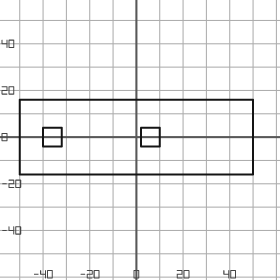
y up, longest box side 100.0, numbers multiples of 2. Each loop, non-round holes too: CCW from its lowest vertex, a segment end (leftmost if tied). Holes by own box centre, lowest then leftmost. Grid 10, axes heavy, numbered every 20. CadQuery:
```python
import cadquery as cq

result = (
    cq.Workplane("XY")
    .moveTo(-50.0, -16.0)
    .lineTo(50.0, -16.0)
    .lineTo(50.0, 16.0)
    .lineTo(-50.0, 16.0)
    .close()
    .moveTo(-40.0, -4.0)
    .lineTo(-32.0, -4.0)
    .lineTo(-32.0, 4.0)
    .lineTo(-40.0, 4.0)
    .close()
    .moveTo(2.0, -4.0)
    .lineTo(10.0, -4.0)
    .lineTo(10.0, 4.0)
    .lineTo(2.0, 4.0)
    .close()
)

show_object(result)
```